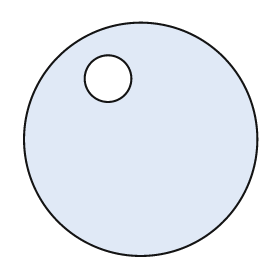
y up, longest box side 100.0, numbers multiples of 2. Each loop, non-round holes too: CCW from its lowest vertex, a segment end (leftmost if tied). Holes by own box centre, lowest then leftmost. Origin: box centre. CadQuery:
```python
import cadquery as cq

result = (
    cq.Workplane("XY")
    .moveTo(0.0, 0.0)
    .circle(50.0)
    .moveTo(-14.0, 26.0)
    .circle(10.0)
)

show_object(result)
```